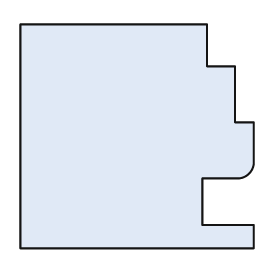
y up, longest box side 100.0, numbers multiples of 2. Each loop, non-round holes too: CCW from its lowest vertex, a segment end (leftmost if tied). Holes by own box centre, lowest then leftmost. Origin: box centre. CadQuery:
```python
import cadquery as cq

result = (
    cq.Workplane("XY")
    .moveTo(-50.0, -48.0)
    .lineTo(50.0, -48.0)
    .lineTo(50.0, -38.0)
    .lineTo(28.0, -38.0)
    .lineTo(28.0, -18.0)
    .lineTo(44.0, -18.0)
    .threePointArc((48.0, -16.0), (50.0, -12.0))
    .lineTo(50.0, 6.0)
    .lineTo(42.0, 6.0)
    .lineTo(42.0, 30.0)
    .lineTo(30.0, 30.0)
    .lineTo(30.0, 48.0)
    .lineTo(-50.0, 48.0)
    .close()
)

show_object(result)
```